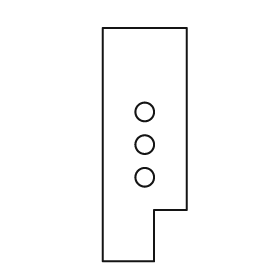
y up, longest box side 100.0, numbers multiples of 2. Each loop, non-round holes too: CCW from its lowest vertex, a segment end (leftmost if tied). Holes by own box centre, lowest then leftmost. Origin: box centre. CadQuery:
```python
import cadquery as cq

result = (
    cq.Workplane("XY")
    .moveTo(-18.0, -50.0)
    .lineTo(4.0, -50.0)
    .lineTo(4.0, -28.0)
    .lineTo(18.0, -28.0)
    .lineTo(18.0, 50.0)
    .lineTo(-18.0, 50.0)
    .close()
    .moveTo(0.0, -14.0)
    .circle(4.0)
    .moveTo(0.0, 0.0)
    .circle(4.0)
    .moveTo(0.0, 14.0)
    .circle(4.0)
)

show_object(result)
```